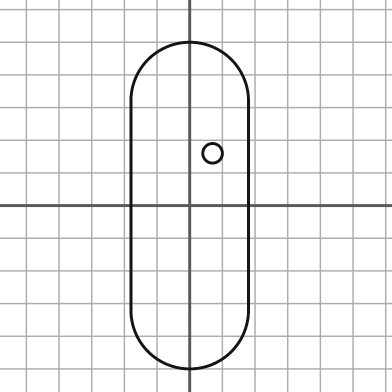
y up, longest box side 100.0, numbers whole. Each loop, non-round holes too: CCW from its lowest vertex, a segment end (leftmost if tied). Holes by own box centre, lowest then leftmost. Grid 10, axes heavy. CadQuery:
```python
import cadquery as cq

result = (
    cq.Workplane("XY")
    .moveTo(-18.0, -32.0)
    .threePointArc((0.0, -50.0), (18.0, -32.0))
    .lineTo(18.0, 32.0)
    .threePointArc((0.0, 50.0), (-18.0, 32.0))
    .close()
    .moveTo(7.0, 16.0)
    .circle(3.0)
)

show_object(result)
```